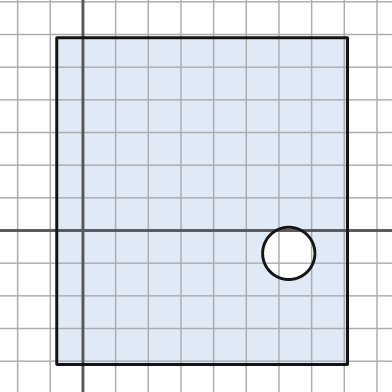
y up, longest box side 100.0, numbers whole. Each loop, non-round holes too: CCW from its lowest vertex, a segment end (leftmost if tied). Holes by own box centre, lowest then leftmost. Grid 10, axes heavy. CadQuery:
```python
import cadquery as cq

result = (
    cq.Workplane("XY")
    .moveTo(-8.0, -41.0)
    .lineTo(81.0, -41.0)
    .lineTo(81.0, 59.0)
    .lineTo(-8.0, 59.0)
    .close()
    .moveTo(63.0, -7.0)
    .circle(8.0)
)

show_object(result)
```